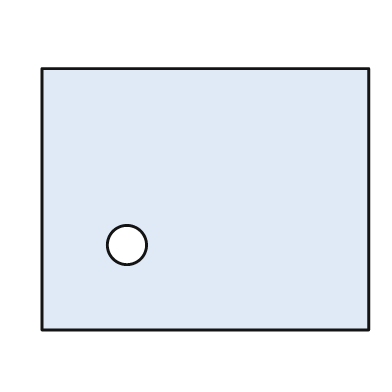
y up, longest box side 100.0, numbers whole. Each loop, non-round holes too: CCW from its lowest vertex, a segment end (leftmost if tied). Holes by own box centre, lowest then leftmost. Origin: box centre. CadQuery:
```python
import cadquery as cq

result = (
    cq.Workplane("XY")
    .moveTo(-50.0, -40.0)
    .lineTo(50.0, -40.0)
    .lineTo(50.0, 40.0)
    .lineTo(-50.0, 40.0)
    .close()
    .moveTo(-24.0, -14.0)
    .circle(6.0)
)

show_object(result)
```